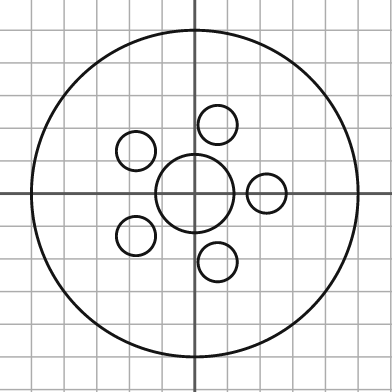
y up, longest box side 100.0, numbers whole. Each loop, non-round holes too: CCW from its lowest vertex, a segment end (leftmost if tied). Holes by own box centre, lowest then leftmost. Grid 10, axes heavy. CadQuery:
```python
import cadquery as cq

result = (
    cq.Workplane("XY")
    .moveTo(0.0, 0.0)
    .circle(50.0)
    .moveTo(7.0, -21.0)
    .circle(6.0)
    .moveTo(-18.0, -13.0)
    .circle(6.0)
    .moveTo(0.0, 0.0)
    .circle(12.0)
    .moveTo(22.0, 0.0)
    .circle(6.0)
    .moveTo(-18.0, 13.0)
    .circle(6.0)
    .moveTo(7.0, 21.0)
    .circle(6.0)
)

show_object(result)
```